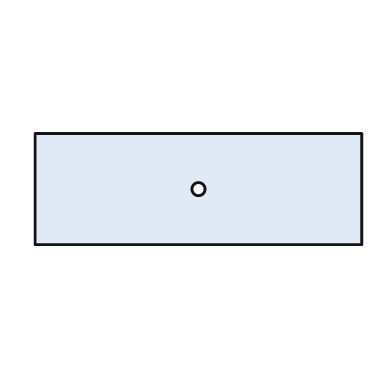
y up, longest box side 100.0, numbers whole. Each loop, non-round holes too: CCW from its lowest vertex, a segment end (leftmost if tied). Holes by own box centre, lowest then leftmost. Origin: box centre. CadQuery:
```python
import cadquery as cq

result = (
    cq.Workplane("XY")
    .moveTo(-50.0, -17.0)
    .lineTo(50.0, -17.0)
    .lineTo(50.0, 17.0)
    .lineTo(-50.0, 17.0)
    .close()
    .moveTo(0.0, 0.0)
    .circle(2.0)
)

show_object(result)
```